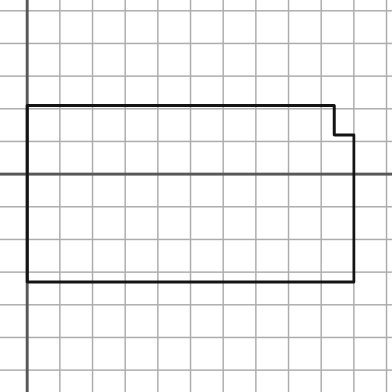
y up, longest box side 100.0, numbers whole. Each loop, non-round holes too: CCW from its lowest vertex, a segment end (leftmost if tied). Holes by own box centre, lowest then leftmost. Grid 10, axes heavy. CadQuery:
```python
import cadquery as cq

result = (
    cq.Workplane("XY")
    .moveTo(0.0, -33.0)
    .lineTo(100.0, -33.0)
    .lineTo(100.0, 12.0)
    .lineTo(94.0, 12.0)
    .lineTo(94.0, 21.0)
    .lineTo(0.0, 21.0)
    .close()
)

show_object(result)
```